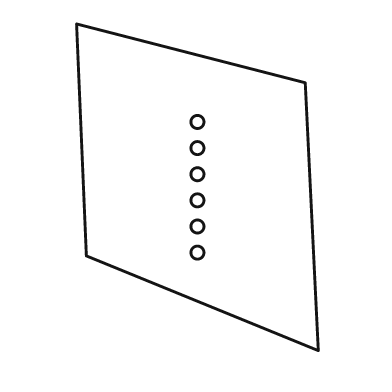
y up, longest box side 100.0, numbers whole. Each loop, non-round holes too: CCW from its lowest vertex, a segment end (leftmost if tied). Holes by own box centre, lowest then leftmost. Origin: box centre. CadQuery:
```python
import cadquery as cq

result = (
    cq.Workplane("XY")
    .moveTo(37.0, -50.0)
    .lineTo(33.0, 32.0)
    .lineTo(-37.0, 50.0)
    .lineTo(-34.0, -21.0)
    .close()
    .moveTo(0.0, -20.0)
    .circle(2.0)
    .moveTo(0.0, -12.0)
    .circle(2.0)
    .moveTo(0.0, -4.0)
    .circle(2.0)
    .moveTo(0.0, 4.0)
    .circle(2.0)
    .moveTo(0.0, 12.0)
    .circle(2.0)
    .moveTo(0.0, 20.0)
    .circle(2.0)
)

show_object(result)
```